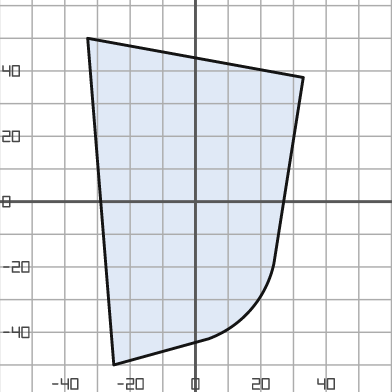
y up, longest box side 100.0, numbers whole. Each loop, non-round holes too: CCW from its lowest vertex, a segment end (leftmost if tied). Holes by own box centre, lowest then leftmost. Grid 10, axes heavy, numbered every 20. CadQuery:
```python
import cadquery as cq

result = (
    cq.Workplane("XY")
    .moveTo(-25.0, -50.0)
    .lineTo(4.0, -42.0)
    .threePointArc((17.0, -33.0), (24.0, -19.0))
    .lineTo(33.0, 38.0)
    .lineTo(-33.0, 50.0)
    .close()
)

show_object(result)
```